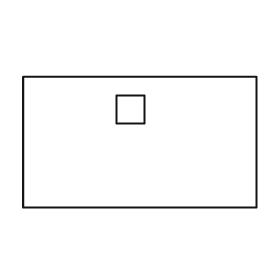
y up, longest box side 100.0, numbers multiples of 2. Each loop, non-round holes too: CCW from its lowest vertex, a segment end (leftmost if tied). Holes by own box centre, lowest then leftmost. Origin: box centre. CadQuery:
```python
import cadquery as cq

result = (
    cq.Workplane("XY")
    .moveTo(-50.0, -28.0)
    .lineTo(50.0, -28.0)
    .lineTo(50.0, 28.0)
    .lineTo(-50.0, 28.0)
    .close()
    .moveTo(-10.0, 8.0)
    .lineTo(2.0, 8.0)
    .lineTo(2.0, 20.0)
    .lineTo(-10.0, 20.0)
    .close()
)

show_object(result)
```